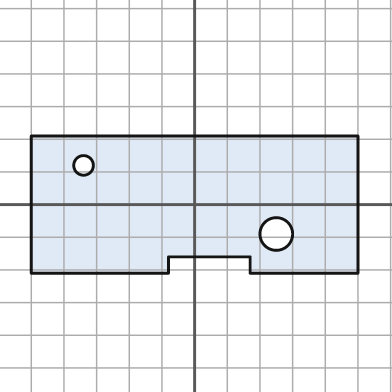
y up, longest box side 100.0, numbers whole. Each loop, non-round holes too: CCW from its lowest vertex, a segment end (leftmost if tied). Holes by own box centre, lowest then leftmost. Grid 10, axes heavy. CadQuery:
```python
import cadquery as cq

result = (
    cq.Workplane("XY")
    .moveTo(-50.0, -21.0)
    .lineTo(-8.0, -21.0)
    .lineTo(-8.0, -16.0)
    .lineTo(17.0, -16.0)
    .lineTo(17.0, -21.0)
    .lineTo(50.0, -21.0)
    .lineTo(50.0, 21.0)
    .lineTo(-50.0, 21.0)
    .close()
    .moveTo(25.0, -9.0)
    .circle(5.0)
    .moveTo(-34.0, 12.0)
    .circle(3.0)
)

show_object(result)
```